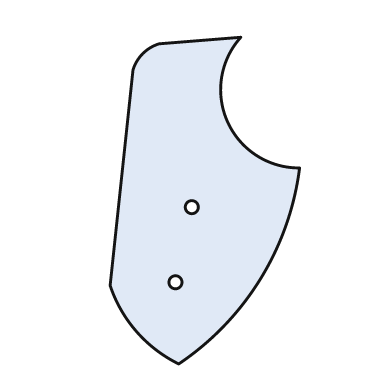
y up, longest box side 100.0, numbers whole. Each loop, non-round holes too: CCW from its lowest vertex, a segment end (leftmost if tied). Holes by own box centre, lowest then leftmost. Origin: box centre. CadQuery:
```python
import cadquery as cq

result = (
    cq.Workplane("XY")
    .moveTo(-8.0, -50.0)
    .threePointArc((17.0, -24.0), (29.0, 10.0))
    .threePointArc((7.0, 24.0), (11.0, 50.0))
    .lineTo(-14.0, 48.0)
    .threePointArc((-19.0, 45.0), (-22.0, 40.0))
    .lineTo(-29.0, -26.0)
    .threePointArc((-21.0, -40.0), (-8.0, -50.0))
    .close()
    .moveTo(-9.0, -25.0)
    .circle(2.0)
    .moveTo(-4.0, -2.0)
    .circle(2.0)
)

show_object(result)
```